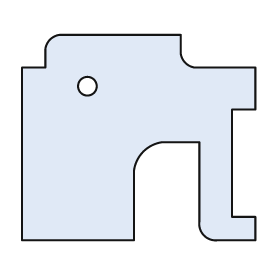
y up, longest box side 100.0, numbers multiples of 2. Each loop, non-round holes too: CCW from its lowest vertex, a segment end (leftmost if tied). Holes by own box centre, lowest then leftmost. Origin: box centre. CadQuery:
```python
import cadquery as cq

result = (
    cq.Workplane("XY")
    .moveTo(-50.0, -44.0)
    .lineTo(-2.0, -44.0)
    .lineTo(-2.0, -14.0)
    .threePointArc((2.0, -6.0), (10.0, -2.0))
    .lineTo(26.0, -2.0)
    .lineTo(26.0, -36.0)
    .threePointArc((28.0, -42.0), (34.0, -44.0))
    .lineTo(50.0, -44.0)
    .lineTo(50.0, -34.0)
    .lineTo(40.0, -34.0)
    .lineTo(40.0, 12.0)
    .lineTo(50.0, 12.0)
    .lineTo(50.0, 30.0)
    .lineTo(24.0, 30.0)
    .threePointArc((20.0, 32.0), (18.0, 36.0))
    .lineTo(18.0, 44.0)
    .lineTo(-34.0, 44.0)
    .threePointArc((-38.0, 42.0), (-40.0, 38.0))
    .lineTo(-40.0, 30.0)
    .lineTo(-50.0, 30.0)
    .close()
    .moveTo(-22.0, 22.0)
    .circle(4.0)
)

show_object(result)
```